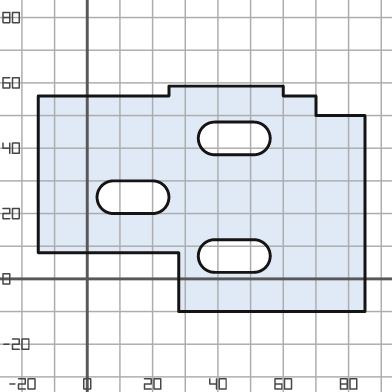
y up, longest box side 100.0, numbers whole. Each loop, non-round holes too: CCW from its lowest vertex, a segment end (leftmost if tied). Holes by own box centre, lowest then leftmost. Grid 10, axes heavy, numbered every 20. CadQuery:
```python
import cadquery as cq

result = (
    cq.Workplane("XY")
    .moveTo(28.0, -10.0)
    .lineTo(85.0, -10.0)
    .lineTo(85.0, 50.0)
    .lineTo(70.0, 50.0)
    .lineTo(70.0, 56.0)
    .lineTo(60.0, 56.0)
    .lineTo(60.0, 59.0)
    .lineTo(25.0, 59.0)
    .lineTo(25.0, 56.0)
    .lineTo(-15.0, 56.0)
    .lineTo(-15.0, 8.0)
    .lineTo(28.0, 8.0)
    .close()
    .moveTo(39.0, 2.0)
    .lineTo(51.0, 2.0)
    .threePointArc((56.0, 7.0), (51.0, 12.0))
    .lineTo(39.0, 12.0)
    .threePointArc((34.0, 7.0), (39.0, 2.0))
    .close()
    .moveTo(8.0, 20.0)
    .lineTo(20.0, 20.0)
    .threePointArc((25.0, 25.0), (20.0, 30.0))
    .lineTo(8.0, 30.0)
    .threePointArc((3.0, 25.0), (8.0, 20.0))
    .close()
    .moveTo(39.0, 38.0)
    .lineTo(51.0, 38.0)
    .threePointArc((56.0, 43.0), (51.0, 48.0))
    .lineTo(39.0, 48.0)
    .threePointArc((34.0, 43.0), (39.0, 38.0))
    .close()
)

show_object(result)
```